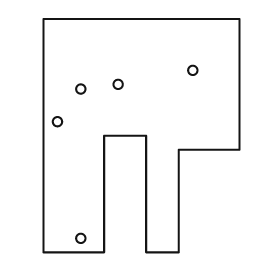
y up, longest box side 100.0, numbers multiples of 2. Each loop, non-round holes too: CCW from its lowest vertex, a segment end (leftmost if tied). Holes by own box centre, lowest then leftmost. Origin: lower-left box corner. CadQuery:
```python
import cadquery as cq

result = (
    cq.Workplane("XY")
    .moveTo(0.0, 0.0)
    .lineTo(26.0, 0.0)
    .lineTo(26.0, 50.0)
    .lineTo(44.0, 50.0)
    .lineTo(44.0, 0.0)
    .lineTo(58.0, 0.0)
    .lineTo(58.0, 44.0)
    .lineTo(84.0, 44.0)
    .lineTo(84.0, 100.0)
    .lineTo(0.0, 100.0)
    .close()
    .moveTo(16.0, 6.0)
    .circle(2.0)
    .moveTo(6.0, 56.0)
    .circle(2.0)
    .moveTo(16.0, 70.0)
    .circle(2.0)
    .moveTo(32.0, 72.0)
    .circle(2.0)
    .moveTo(64.0, 78.0)
    .circle(2.0)
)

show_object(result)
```